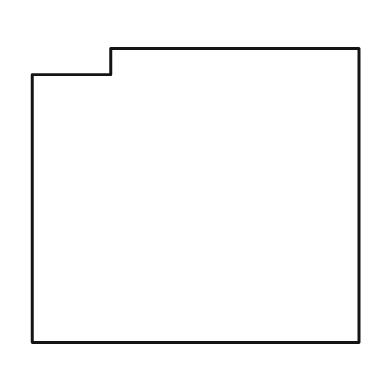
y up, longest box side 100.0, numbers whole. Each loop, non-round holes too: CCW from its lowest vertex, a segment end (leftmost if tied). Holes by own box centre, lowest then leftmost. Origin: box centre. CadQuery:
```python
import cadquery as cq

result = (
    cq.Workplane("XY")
    .moveTo(-50.0, -45.0)
    .lineTo(50.0, -45.0)
    .lineTo(50.0, 45.0)
    .lineTo(-26.0, 45.0)
    .lineTo(-26.0, 37.0)
    .lineTo(-50.0, 37.0)
    .close()
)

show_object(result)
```